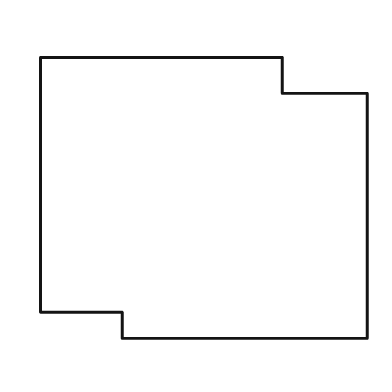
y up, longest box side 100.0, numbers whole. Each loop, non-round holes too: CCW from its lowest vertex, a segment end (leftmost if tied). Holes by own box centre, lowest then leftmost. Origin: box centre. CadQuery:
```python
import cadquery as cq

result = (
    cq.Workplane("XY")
    .moveTo(-25.0, -43.0)
    .lineTo(50.0, -43.0)
    .lineTo(50.0, 32.0)
    .lineTo(24.0, 32.0)
    .lineTo(24.0, 43.0)
    .lineTo(-50.0, 43.0)
    .lineTo(-50.0, -35.0)
    .lineTo(-25.0, -35.0)
    .close()
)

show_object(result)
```